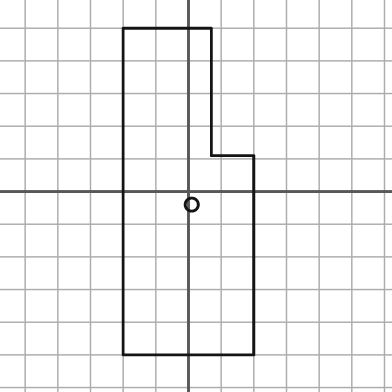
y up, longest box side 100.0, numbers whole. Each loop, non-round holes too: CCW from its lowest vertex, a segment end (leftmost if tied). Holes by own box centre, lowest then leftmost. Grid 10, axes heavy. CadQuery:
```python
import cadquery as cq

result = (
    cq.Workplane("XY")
    .moveTo(-20.0, -50.0)
    .lineTo(20.0, -50.0)
    .lineTo(20.0, 11.0)
    .lineTo(7.0, 11.0)
    .lineTo(7.0, 50.0)
    .lineTo(-20.0, 50.0)
    .close()
    .moveTo(1.0, -4.0)
    .circle(2.0)
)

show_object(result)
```